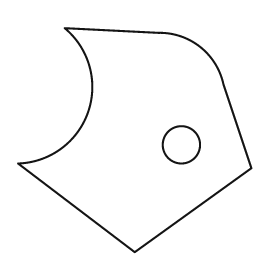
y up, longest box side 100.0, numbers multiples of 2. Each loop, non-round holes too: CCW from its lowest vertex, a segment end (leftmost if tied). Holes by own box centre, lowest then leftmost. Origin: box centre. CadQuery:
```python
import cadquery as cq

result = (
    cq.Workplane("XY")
    .moveTo(0.0, -48.0)
    .lineTo(50.0, -12.0)
    .lineTo(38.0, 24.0)
    .threePointArc((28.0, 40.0), (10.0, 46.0))
    .lineTo(-30.0, 48.0)
    .threePointArc((-20.0, 12.0), (-50.0, -10.0))
    .close()
    .moveTo(20.0, -2.0)
    .circle(8.0)
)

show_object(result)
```